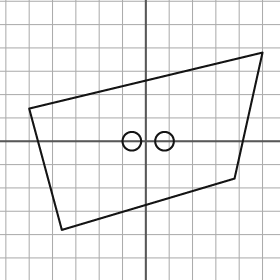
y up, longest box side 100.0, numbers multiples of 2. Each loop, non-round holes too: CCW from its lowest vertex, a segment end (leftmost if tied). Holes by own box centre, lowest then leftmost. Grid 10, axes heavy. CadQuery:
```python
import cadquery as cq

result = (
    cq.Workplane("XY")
    .moveTo(-36.0, -38.0)
    .lineTo(38.0, -16.0)
    .lineTo(50.0, 38.0)
    .lineTo(-50.0, 14.0)
    .close()
    .moveTo(-6.0, 0.0)
    .circle(4.0)
    .moveTo(8.0, 0.0)
    .circle(4.0)
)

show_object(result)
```